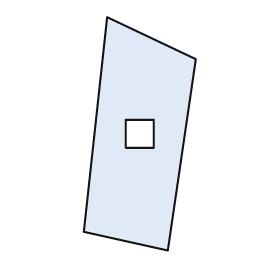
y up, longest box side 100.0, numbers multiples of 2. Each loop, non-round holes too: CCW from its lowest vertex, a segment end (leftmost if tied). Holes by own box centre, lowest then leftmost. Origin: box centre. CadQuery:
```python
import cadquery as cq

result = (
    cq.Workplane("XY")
    .moveTo(12.0, -50.0)
    .lineTo(24.0, 32.0)
    .lineTo(-14.0, 50.0)
    .lineTo(-24.0, -42.0)
    .close()
    .moveTo(-6.0, -6.0)
    .lineTo(6.0, -6.0)
    .lineTo(6.0, 6.0)
    .lineTo(-6.0, 6.0)
    .close()
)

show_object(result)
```